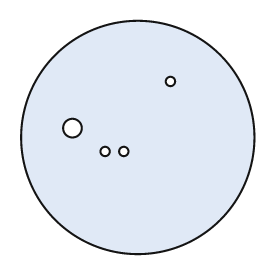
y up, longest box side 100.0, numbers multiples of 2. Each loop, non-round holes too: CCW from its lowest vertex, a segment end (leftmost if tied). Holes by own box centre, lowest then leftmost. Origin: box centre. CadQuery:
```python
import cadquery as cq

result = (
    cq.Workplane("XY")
    .moveTo(0.0, 0.0)
    .circle(50.0)
    .moveTo(-14.0, -6.0)
    .circle(2.0)
    .moveTo(-6.0, -6.0)
    .circle(2.0)
    .moveTo(-28.0, 4.0)
    .circle(4.0)
    .moveTo(14.0, 24.0)
    .circle(2.0)
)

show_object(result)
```